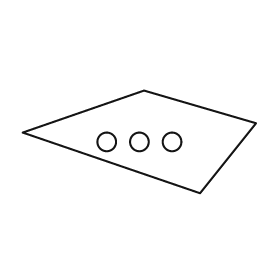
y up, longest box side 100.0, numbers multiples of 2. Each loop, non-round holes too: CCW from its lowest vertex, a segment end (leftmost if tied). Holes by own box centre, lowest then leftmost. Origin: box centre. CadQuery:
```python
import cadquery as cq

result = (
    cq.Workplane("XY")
    .moveTo(26.0, -22.0)
    .lineTo(50.0, 8.0)
    .lineTo(2.0, 22.0)
    .lineTo(-50.0, 4.0)
    .close()
    .moveTo(-14.0, 0.0)
    .circle(4.0)
    .moveTo(0.0, 0.0)
    .circle(4.0)
    .moveTo(14.0, 0.0)
    .circle(4.0)
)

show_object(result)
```